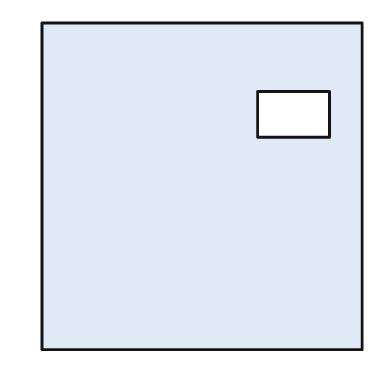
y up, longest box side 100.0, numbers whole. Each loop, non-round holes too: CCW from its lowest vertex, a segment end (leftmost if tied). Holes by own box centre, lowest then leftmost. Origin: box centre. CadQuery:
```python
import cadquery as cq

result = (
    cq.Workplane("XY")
    .moveTo(-49.0, -50.0)
    .lineTo(49.0, -50.0)
    .lineTo(49.0, 50.0)
    .lineTo(-49.0, 50.0)
    .close()
    .moveTo(17.0, 15.0)
    .lineTo(39.0, 15.0)
    .lineTo(39.0, 29.0)
    .lineTo(17.0, 29.0)
    .close()
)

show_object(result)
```